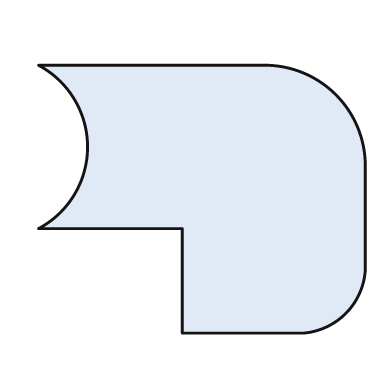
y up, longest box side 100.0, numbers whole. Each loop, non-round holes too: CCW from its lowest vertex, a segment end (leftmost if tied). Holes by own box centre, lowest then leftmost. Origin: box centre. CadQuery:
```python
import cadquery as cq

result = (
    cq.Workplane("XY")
    .moveTo(-6.0, -41.0)
    .lineTo(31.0, -41.0)
    .threePointArc((44.0, -35.0), (50.0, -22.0))
    .lineTo(50.0, 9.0)
    .threePointArc((41.0, 32.0), (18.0, 41.0))
    .lineTo(-50.0, 41.0)
    .threePointArc((-35.0, 16.0), (-50.0, -9.0))
    .lineTo(-6.0, -9.0)
    .close()
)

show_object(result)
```